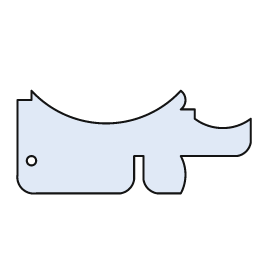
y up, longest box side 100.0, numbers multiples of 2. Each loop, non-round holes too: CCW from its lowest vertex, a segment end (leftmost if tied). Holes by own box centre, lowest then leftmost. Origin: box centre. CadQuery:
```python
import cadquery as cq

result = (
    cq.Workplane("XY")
    .moveTo(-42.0, -22.0)
    .lineTo(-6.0, -22.0)
    .threePointArc((-2.0, -20.0), (0.0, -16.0))
    .lineTo(0.0, -6.0)
    .lineTo(4.0, -6.0)
    .lineTo(4.0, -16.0)
    .threePointArc((6.0, -20.0), (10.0, -22.0))
    .lineTo(20.0, -22.0)
    .threePointArc((22.0, -14.0), (20.0, -6.0))
    .lineTo(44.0, -6.0)
    .threePointArc((48.0, -4.0), (50.0, 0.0))
    .lineTo(50.0, 10.0)
    .threePointArc((38.0, 6.0), (26.0, 10.0))
    .lineTo(26.0, 14.0)
    .lineTo(20.0, 14.0)
    .threePointArc((22.0, 18.0), (20.0, 22.0))
    .threePointArc((-12.0, 8.0), (-44.0, 22.0))
    .lineTo(-44.0, 18.0)
    .lineTo(-50.0, 18.0)
    .lineTo(-50.0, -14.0)
    .threePointArc((-48.0, -20.0), (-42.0, -22.0))
    .close()
    .moveTo(-44.0, -8.0)
    .circle(2.0)
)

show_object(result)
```